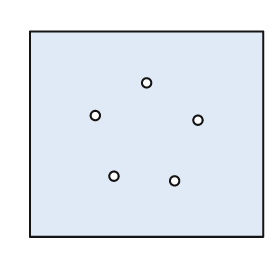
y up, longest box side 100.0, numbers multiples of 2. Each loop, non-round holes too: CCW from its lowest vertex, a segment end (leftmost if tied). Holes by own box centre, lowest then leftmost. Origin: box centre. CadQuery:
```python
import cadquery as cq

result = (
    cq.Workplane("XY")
    .moveTo(-50.0, -44.0)
    .lineTo(50.0, -44.0)
    .lineTo(50.0, 44.0)
    .lineTo(-50.0, 44.0)
    .close()
    .moveTo(12.0, -20.0)
    .circle(2.0)
    .moveTo(-14.0, -18.0)
    .circle(2.0)
    .moveTo(22.0, 6.0)
    .circle(2.0)
    .moveTo(-22.0, 8.0)
    .circle(2.0)
    .moveTo(0.0, 22.0)
    .circle(2.0)
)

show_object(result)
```